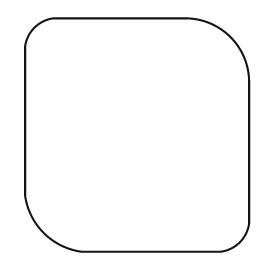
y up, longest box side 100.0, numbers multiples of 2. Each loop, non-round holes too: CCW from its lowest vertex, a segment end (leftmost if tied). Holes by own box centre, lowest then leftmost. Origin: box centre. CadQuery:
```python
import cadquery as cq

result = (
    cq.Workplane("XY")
    .moveTo(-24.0, -50.0)
    .lineTo(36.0, -50.0)
    .threePointArc((44.0, -46.0), (48.0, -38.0))
    .lineTo(48.0, 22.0)
    .threePointArc((40.0, 42.0), (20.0, 50.0))
    .lineTo(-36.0, 50.0)
    .threePointArc((-44.0, 46.0), (-48.0, 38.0))
    .lineTo(-48.0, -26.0)
    .threePointArc((-40.0, -42.0), (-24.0, -50.0))
    .close()
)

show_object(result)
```